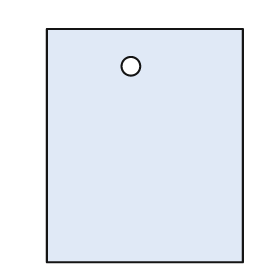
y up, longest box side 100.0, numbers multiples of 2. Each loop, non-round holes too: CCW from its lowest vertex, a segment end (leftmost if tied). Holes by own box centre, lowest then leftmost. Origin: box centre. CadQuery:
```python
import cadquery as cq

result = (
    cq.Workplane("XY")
    .moveTo(-42.0, -50.0)
    .lineTo(42.0, -50.0)
    .lineTo(42.0, 50.0)
    .lineTo(-42.0, 50.0)
    .close()
    .moveTo(-6.0, 34.0)
    .circle(4.0)
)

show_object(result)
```